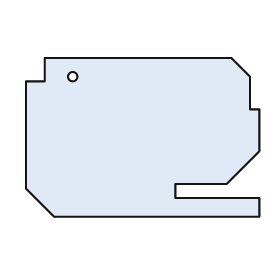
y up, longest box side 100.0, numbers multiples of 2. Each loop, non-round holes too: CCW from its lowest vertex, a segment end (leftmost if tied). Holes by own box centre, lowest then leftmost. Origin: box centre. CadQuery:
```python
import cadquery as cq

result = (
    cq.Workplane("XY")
    .moveTo(-38.0, -34.0)
    .lineTo(50.0, -34.0)
    .lineTo(50.0, -26.0)
    .lineTo(14.0, -26.0)
    .lineTo(14.0, -20.0)
    .lineTo(36.0, -20.0)
    .lineTo(50.0, -6.0)
    .lineTo(50.0, 12.0)
    .lineTo(46.0, 12.0)
    .lineTo(46.0, 26.0)
    .lineTo(38.0, 34.0)
    .lineTo(-42.0, 34.0)
    .lineTo(-42.0, 24.0)
    .lineTo(-50.0, 24.0)
    .lineTo(-50.0, -22.0)
    .close()
    .moveTo(-30.0, 26.0)
    .circle(2.0)
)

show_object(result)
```